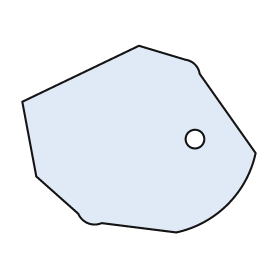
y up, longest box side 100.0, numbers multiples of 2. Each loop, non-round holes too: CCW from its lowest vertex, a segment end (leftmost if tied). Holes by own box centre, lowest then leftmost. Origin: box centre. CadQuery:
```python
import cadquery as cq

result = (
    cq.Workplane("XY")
    .moveTo(16.0, -40.0)
    .threePointArc((38.0, -28.0), (50.0, -6.0))
    .lineTo(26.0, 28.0)
    .threePointArc((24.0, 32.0), (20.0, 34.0))
    .lineTo(0.0, 40.0)
    .lineTo(-50.0, 16.0)
    .lineTo(-44.0, -16.0)
    .lineTo(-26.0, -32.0)
    .threePointArc((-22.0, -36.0), (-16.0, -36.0))
    .close()
    .moveTo(24.0, 0.0)
    .circle(4.0)
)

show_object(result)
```